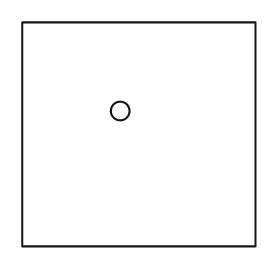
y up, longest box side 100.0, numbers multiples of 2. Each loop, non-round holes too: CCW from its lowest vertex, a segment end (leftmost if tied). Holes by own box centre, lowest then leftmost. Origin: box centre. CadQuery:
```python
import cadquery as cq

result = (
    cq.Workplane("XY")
    .moveTo(-50.0, -48.0)
    .lineTo(50.0, -48.0)
    .lineTo(50.0, 48.0)
    .lineTo(-50.0, 48.0)
    .close()
    .moveTo(-8.0, 10.0)
    .circle(4.0)
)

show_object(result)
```